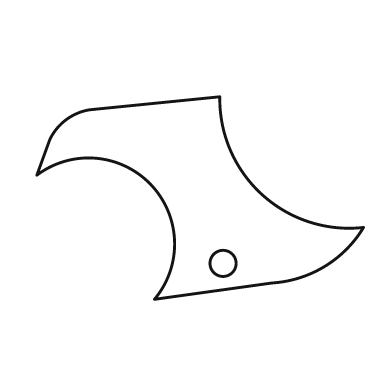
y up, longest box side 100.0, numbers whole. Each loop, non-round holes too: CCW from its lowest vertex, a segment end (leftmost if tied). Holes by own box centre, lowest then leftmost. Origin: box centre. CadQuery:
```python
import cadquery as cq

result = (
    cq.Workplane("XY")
    .moveTo(-14.0, -31.0)
    .lineTo(22.0, -26.0)
    .threePointArc((38.0, -21.0), (50.0, -9.0))
    .threePointArc((19.0, 1.0), (6.0, 31.0))
    .lineTo(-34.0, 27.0)
    .threePointArc((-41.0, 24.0), (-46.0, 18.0))
    .lineTo(-50.0, 7.0)
    .threePointArc((-15.0, 4.0), (-14.0, -31.0))
    .close()
    .moveTo(7.0, -20.0)
    .circle(4.0)
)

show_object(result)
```